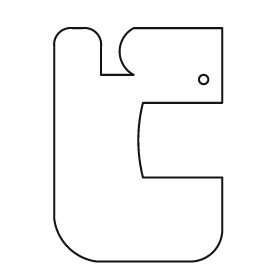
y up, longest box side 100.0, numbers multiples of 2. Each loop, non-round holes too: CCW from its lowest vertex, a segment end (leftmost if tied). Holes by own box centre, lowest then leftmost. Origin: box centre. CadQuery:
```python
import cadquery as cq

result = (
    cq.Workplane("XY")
    .moveTo(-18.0, -50.0)
    .lineTo(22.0, -50.0)
    .threePointArc((32.0, -46.0), (36.0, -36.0))
    .lineTo(36.0, -14.0)
    .lineTo(2.0, -14.0)
    .threePointArc((0.0, 2.0), (2.0, 18.0))
    .lineTo(36.0, 18.0)
    .lineTo(36.0, 50.0)
    .lineTo(-2.0, 50.0)
    .threePointArc((-8.0, 40.0), (-2.0, 30.0))
    .lineTo(-16.0, 30.0)
    .lineTo(-16.0, 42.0)
    .threePointArc((-18.0, 48.0), (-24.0, 50.0))
    .lineTo(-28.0, 50.0)
    .threePointArc((-34.0, 48.0), (-36.0, 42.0))
    .lineTo(-36.0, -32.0)
    .threePointArc((-30.0, -44.0), (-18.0, -50.0))
    .close()
    .moveTo(28.0, 28.0)
    .circle(2.0)
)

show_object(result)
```